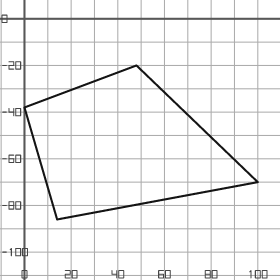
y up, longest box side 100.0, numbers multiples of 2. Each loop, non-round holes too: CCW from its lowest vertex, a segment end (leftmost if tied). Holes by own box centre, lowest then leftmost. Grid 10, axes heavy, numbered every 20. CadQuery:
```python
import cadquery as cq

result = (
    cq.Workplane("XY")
    .moveTo(14.0, -86.0)
    .lineTo(100.0, -70.0)
    .lineTo(48.0, -20.0)
    .lineTo(0.0, -38.0)
    .close()
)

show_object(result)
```